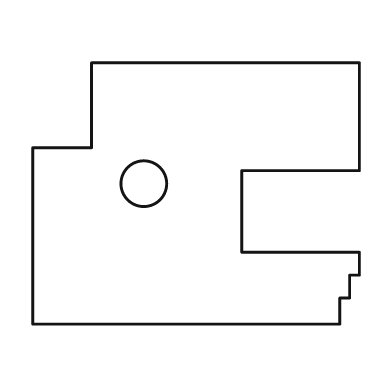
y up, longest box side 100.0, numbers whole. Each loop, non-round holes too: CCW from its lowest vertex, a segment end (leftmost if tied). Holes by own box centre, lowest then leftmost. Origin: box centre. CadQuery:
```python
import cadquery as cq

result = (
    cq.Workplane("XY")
    .moveTo(-50.0, -40.0)
    .lineTo(44.0, -40.0)
    .lineTo(44.0, -32.0)
    .lineTo(47.0, -32.0)
    .lineTo(47.0, -25.0)
    .lineTo(50.0, -25.0)
    .lineTo(50.0, -18.0)
    .lineTo(14.0, -18.0)
    .lineTo(14.0, 7.0)
    .lineTo(50.0, 7.0)
    .lineTo(50.0, 40.0)
    .lineTo(-32.0, 40.0)
    .lineTo(-32.0, 14.0)
    .lineTo(-50.0, 14.0)
    .close()
    .moveTo(-16.0, 3.0)
    .circle(7.0)
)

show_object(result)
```